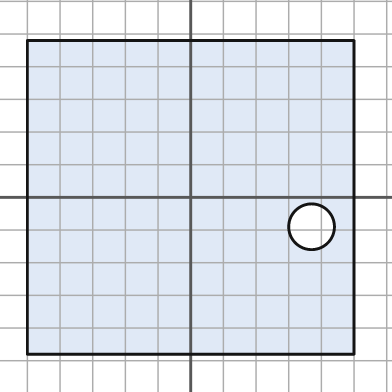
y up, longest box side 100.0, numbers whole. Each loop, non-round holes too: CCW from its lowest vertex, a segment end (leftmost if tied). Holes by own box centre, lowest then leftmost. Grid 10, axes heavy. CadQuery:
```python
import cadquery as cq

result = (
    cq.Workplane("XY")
    .moveTo(-50.0, -48.0)
    .lineTo(50.0, -48.0)
    .lineTo(50.0, 48.0)
    .lineTo(-50.0, 48.0)
    .close()
    .moveTo(37.0, -9.0)
    .circle(7.0)
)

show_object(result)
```